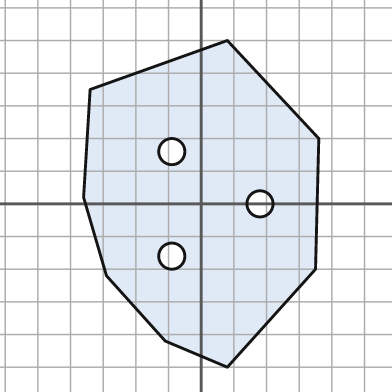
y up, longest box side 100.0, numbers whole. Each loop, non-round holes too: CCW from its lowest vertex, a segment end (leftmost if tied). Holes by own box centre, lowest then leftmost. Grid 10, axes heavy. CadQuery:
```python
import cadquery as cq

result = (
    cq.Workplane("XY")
    .moveTo(8.0, -50.0)
    .lineTo(35.0, -20.0)
    .lineTo(36.0, 20.0)
    .lineTo(8.0, 50.0)
    .lineTo(-34.0, 35.0)
    .lineTo(-36.0, 2.0)
    .lineTo(-29.0, -22.0)
    .lineTo(-11.0, -42.0)
    .close()
    .moveTo(-9.0, -16.0)
    .circle(4.0)
    .moveTo(18.0, 0.0)
    .circle(4.0)
    .moveTo(-9.0, 16.0)
    .circle(4.0)
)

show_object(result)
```